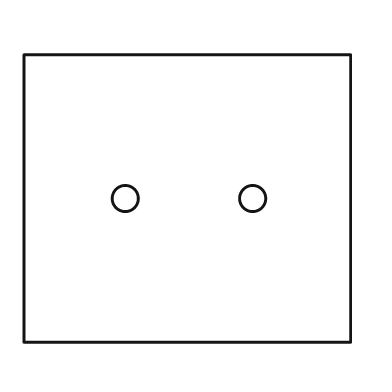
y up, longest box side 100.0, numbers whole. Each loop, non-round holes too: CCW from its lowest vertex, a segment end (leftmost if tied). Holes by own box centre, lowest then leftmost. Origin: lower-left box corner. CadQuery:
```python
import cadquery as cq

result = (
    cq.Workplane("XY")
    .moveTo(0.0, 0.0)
    .lineTo(100.0, 0.0)
    .lineTo(100.0, 88.0)
    .lineTo(0.0, 88.0)
    .close()
    .moveTo(31.0, 44.0)
    .circle(4.0)
    .moveTo(70.0, 44.0)
    .circle(4.0)
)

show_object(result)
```